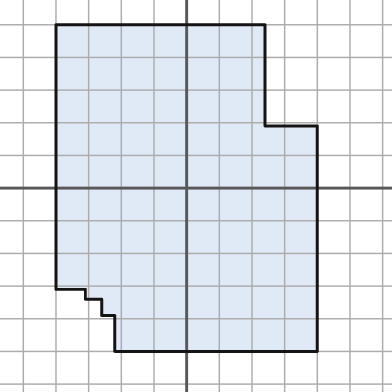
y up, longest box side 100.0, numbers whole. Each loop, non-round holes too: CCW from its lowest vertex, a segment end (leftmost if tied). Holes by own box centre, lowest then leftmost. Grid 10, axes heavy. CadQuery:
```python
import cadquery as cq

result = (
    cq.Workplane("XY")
    .moveTo(-22.0, -50.0)
    .lineTo(40.0, -50.0)
    .lineTo(40.0, 19.0)
    .lineTo(24.0, 19.0)
    .lineTo(24.0, 50.0)
    .lineTo(-40.0, 50.0)
    .lineTo(-40.0, -31.0)
    .lineTo(-31.0, -31.0)
    .lineTo(-31.0, -34.0)
    .lineTo(-26.0, -34.0)
    .lineTo(-26.0, -39.0)
    .lineTo(-22.0, -39.0)
    .close()
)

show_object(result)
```